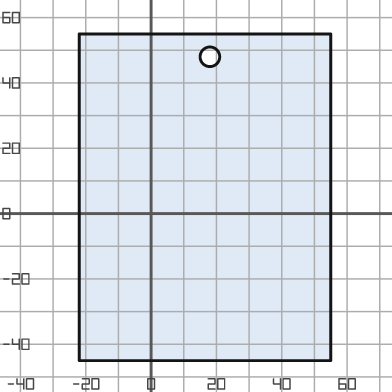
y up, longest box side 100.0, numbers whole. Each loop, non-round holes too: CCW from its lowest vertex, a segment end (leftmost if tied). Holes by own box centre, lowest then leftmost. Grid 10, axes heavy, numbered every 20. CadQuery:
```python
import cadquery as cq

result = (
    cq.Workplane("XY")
    .moveTo(-22.0, -45.0)
    .lineTo(55.0, -45.0)
    .lineTo(55.0, 55.0)
    .lineTo(-22.0, 55.0)
    .close()
    .moveTo(18.0, 48.0)
    .circle(3.0)
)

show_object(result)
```